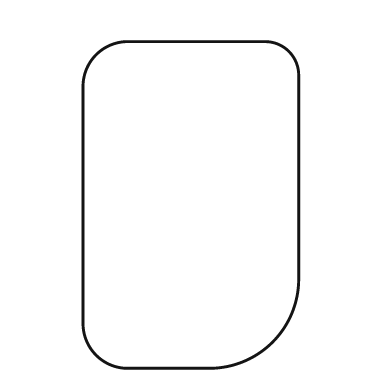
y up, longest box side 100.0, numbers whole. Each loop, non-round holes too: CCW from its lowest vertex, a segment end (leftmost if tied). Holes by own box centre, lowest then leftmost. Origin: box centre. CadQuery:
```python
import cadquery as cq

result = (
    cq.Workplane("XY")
    .moveTo(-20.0, -50.0)
    .lineTo(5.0, -50.0)
    .threePointArc((25.0, -42.0), (33.0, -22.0))
    .lineTo(33.0, 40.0)
    .threePointArc((30.0, 47.0), (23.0, 50.0))
    .lineTo(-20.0, 50.0)
    .threePointArc((-29.0, 46.0), (-33.0, 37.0))
    .lineTo(-33.0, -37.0)
    .threePointArc((-29.0, -46.0), (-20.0, -50.0))
    .close()
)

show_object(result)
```